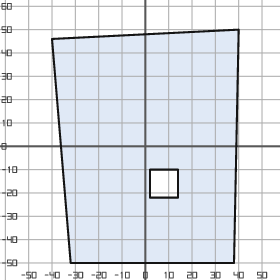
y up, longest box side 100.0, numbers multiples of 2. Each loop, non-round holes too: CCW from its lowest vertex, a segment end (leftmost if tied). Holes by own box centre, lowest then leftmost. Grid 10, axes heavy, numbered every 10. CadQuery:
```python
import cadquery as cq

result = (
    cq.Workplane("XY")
    .moveTo(-32.0, -50.0)
    .lineTo(38.0, -50.0)
    .lineTo(40.0, 50.0)
    .lineTo(-40.0, 46.0)
    .close()
    .moveTo(2.0, -22.0)
    .lineTo(14.0, -22.0)
    .lineTo(14.0, -10.0)
    .lineTo(2.0, -10.0)
    .close()
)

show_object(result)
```